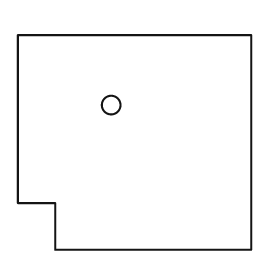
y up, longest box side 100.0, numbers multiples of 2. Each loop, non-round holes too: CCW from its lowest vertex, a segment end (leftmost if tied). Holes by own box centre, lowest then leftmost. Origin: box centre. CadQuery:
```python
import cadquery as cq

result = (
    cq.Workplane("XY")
    .moveTo(-34.0, -46.0)
    .lineTo(50.0, -46.0)
    .lineTo(50.0, 46.0)
    .lineTo(-50.0, 46.0)
    .lineTo(-50.0, -26.0)
    .lineTo(-34.0, -26.0)
    .close()
    .moveTo(-10.0, 16.0)
    .circle(4.0)
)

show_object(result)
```